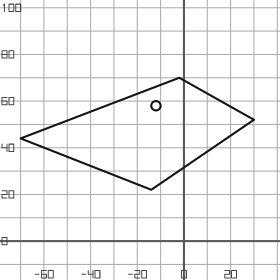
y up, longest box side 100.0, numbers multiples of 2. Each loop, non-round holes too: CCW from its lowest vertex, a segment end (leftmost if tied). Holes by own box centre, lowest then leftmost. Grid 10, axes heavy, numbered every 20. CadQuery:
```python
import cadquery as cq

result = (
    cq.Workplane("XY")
    .moveTo(-14.0, 22.0)
    .lineTo(30.0, 52.0)
    .lineTo(-2.0, 70.0)
    .lineTo(-70.0, 44.0)
    .close()
    .moveTo(-12.0, 58.0)
    .circle(2.0)
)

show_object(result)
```